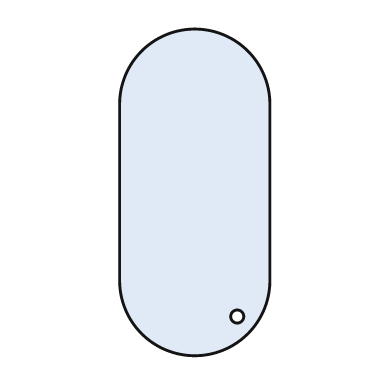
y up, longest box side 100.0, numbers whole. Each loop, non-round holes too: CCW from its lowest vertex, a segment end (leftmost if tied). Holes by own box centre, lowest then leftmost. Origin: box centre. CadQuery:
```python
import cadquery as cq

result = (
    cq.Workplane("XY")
    .moveTo(-23.0, -27.0)
    .threePointArc((0.0, -50.0), (23.0, -27.0))
    .lineTo(23.0, 27.0)
    .threePointArc((0.0, 50.0), (-23.0, 27.0))
    .close()
    .moveTo(13.0, -38.0)
    .circle(2.0)
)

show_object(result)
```